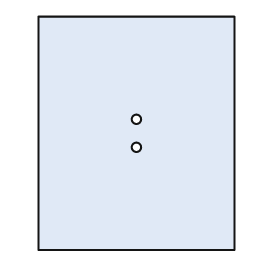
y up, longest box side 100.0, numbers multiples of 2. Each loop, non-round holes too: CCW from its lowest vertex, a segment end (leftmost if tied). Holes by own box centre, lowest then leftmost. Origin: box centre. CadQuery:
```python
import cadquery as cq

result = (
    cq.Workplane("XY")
    .moveTo(-42.0, -50.0)
    .lineTo(42.0, -50.0)
    .lineTo(42.0, 50.0)
    .lineTo(-42.0, 50.0)
    .close()
    .moveTo(0.0, -6.0)
    .circle(2.0)
    .moveTo(0.0, 6.0)
    .circle(2.0)
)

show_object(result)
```